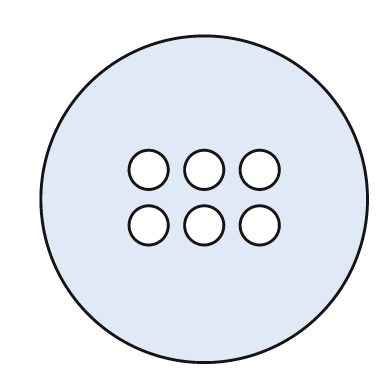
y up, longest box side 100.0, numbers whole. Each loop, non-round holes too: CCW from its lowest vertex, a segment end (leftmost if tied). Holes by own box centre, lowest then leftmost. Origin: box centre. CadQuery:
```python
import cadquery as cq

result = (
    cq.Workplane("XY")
    .moveTo(0.0, 0.0)
    .circle(50.0)
    .moveTo(-17.0, -8.0)
    .circle(6.0)
    .moveTo(0.0, -8.0)
    .circle(6.0)
    .moveTo(17.0, -8.0)
    .circle(6.0)
    .moveTo(-17.0, 9.0)
    .circle(6.0)
    .moveTo(0.0, 9.0)
    .circle(6.0)
    .moveTo(17.0, 9.0)
    .circle(6.0)
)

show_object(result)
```